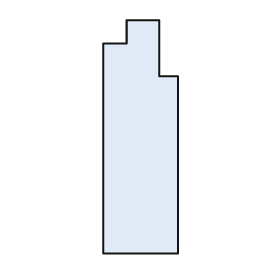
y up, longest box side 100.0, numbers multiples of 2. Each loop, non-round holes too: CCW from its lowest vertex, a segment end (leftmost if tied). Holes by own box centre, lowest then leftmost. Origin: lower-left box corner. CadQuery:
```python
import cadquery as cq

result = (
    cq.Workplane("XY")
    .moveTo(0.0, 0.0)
    .lineTo(32.0, 0.0)
    .lineTo(32.0, 76.0)
    .lineTo(24.0, 76.0)
    .lineTo(24.0, 100.0)
    .lineTo(10.0, 100.0)
    .lineTo(10.0, 90.0)
    .lineTo(0.0, 90.0)
    .close()
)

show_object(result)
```